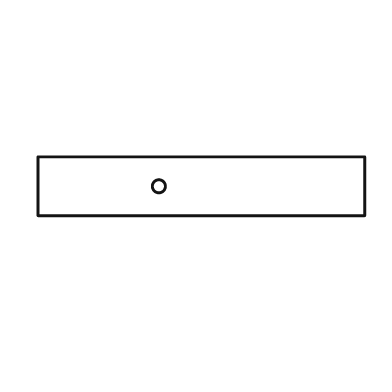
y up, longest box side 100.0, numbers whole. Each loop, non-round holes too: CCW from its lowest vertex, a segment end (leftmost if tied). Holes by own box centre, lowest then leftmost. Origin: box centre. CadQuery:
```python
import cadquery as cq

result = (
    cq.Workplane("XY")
    .moveTo(-50.0, -9.0)
    .lineTo(50.0, -9.0)
    .lineTo(50.0, 9.0)
    .lineTo(-50.0, 9.0)
    .close()
    .moveTo(-13.0, 0.0)
    .circle(2.0)
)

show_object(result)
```